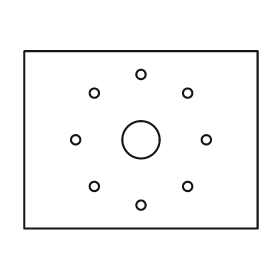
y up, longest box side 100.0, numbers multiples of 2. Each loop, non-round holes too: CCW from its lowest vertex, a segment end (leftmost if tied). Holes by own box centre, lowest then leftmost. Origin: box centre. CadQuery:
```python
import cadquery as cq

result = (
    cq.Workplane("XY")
    .moveTo(-50.0, -38.0)
    .lineTo(50.0, -38.0)
    .lineTo(50.0, 38.0)
    .lineTo(-50.0, 38.0)
    .close()
    .moveTo(0.0, -28.0)
    .circle(2.0)
    .moveTo(-20.0, -20.0)
    .circle(2.0)
    .moveTo(20.0, -20.0)
    .circle(2.0)
    .moveTo(-28.0, 0.0)
    .circle(2.0)
    .moveTo(0.0, 0.0)
    .circle(8.0)
    .moveTo(28.0, 0.0)
    .circle(2.0)
    .moveTo(-20.0, 20.0)
    .circle(2.0)
    .moveTo(20.0, 20.0)
    .circle(2.0)
    .moveTo(0.0, 28.0)
    .circle(2.0)
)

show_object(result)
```